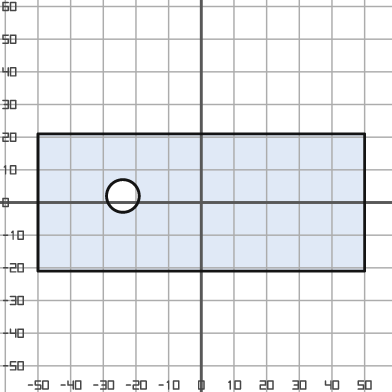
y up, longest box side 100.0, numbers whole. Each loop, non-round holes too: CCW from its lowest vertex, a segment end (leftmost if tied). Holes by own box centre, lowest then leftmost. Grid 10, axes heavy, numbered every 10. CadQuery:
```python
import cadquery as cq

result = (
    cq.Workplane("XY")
    .moveTo(-50.0, -21.0)
    .lineTo(50.0, -21.0)
    .lineTo(50.0, 21.0)
    .lineTo(-50.0, 21.0)
    .close()
    .moveTo(-24.0, 2.0)
    .circle(5.0)
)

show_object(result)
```